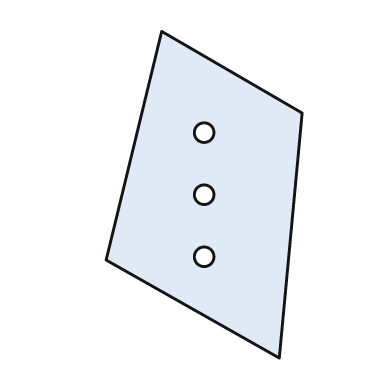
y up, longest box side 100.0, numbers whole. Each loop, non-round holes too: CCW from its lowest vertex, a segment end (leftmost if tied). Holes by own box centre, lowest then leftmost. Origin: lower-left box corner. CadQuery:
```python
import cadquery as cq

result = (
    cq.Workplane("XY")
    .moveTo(53.0, 0.0)
    .lineTo(60.0, 75.0)
    .lineTo(17.0, 100.0)
    .lineTo(0.0, 30.0)
    .close()
    .moveTo(30.0, 31.0)
    .circle(3.0)
    .moveTo(30.0, 50.0)
    .circle(3.0)
    .moveTo(30.0, 69.0)
    .circle(3.0)
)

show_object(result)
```